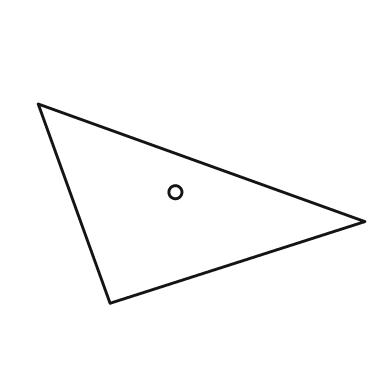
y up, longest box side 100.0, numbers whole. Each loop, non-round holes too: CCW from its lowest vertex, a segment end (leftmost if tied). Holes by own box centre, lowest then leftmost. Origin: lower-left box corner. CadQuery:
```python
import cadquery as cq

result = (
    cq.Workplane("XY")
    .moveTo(22.0, 0.0)
    .lineTo(100.0, 25.0)
    .lineTo(0.0, 61.0)
    .close()
    .moveTo(42.0, 34.0)
    .circle(2.0)
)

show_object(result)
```